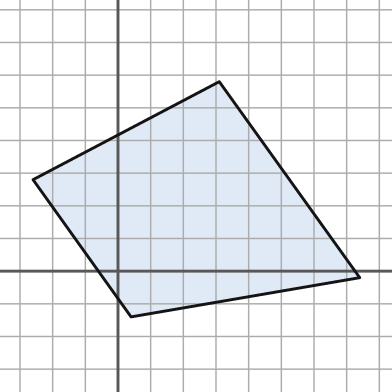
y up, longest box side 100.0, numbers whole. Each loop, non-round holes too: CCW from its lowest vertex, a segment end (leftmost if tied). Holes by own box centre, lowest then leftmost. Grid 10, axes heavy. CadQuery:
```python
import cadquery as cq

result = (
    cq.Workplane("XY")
    .moveTo(4.0, -14.0)
    .lineTo(74.0, -2.0)
    .lineTo(31.0, 58.0)
    .lineTo(-26.0, 28.0)
    .close()
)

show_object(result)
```